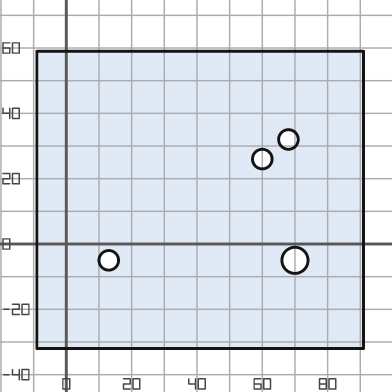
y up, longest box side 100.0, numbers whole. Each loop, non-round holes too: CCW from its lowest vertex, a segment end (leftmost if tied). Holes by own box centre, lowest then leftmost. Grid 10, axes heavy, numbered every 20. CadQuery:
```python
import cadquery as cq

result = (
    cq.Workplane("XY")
    .moveTo(-9.0, -32.0)
    .lineTo(91.0, -32.0)
    .lineTo(91.0, 59.0)
    .lineTo(-9.0, 59.0)
    .close()
    .moveTo(13.0, -5.0)
    .circle(3.0)
    .moveTo(70.0, -5.0)
    .circle(4.0)
    .moveTo(60.0, 26.0)
    .circle(3.0)
    .moveTo(68.0, 32.0)
    .circle(3.0)
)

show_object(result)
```